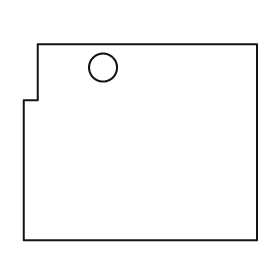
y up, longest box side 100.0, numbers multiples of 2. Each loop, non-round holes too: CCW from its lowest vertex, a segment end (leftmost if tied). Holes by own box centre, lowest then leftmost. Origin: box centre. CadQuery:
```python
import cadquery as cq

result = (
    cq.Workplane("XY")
    .moveTo(-50.0, -42.0)
    .lineTo(50.0, -42.0)
    .lineTo(50.0, 42.0)
    .lineTo(-44.0, 42.0)
    .lineTo(-44.0, 18.0)
    .lineTo(-50.0, 18.0)
    .close()
    .moveTo(-16.0, 32.0)
    .circle(6.0)
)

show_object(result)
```